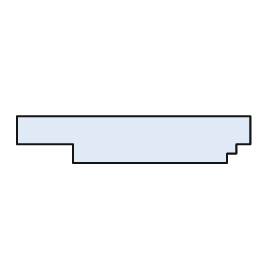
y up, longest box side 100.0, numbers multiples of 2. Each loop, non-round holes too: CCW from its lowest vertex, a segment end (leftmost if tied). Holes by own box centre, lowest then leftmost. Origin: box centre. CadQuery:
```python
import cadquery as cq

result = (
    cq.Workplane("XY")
    .moveTo(-26.0, -10.0)
    .lineTo(40.0, -10.0)
    .lineTo(40.0, -6.0)
    .lineTo(44.0, -6.0)
    .lineTo(44.0, -2.0)
    .lineTo(50.0, -2.0)
    .lineTo(50.0, 10.0)
    .lineTo(-50.0, 10.0)
    .lineTo(-50.0, -2.0)
    .lineTo(-26.0, -2.0)
    .close()
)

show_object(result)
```